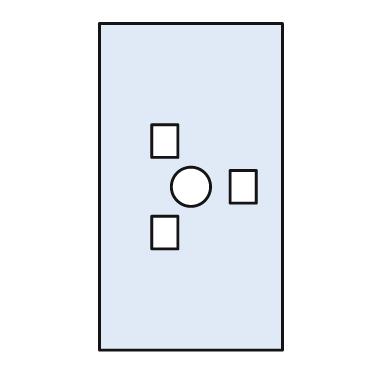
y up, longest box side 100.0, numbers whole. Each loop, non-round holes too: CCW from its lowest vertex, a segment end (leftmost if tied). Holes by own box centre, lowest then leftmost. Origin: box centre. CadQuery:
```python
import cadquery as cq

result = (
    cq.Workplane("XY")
    .moveTo(-28.0, -50.0)
    .lineTo(28.0, -50.0)
    .lineTo(28.0, 50.0)
    .lineTo(-28.0, 50.0)
    .close()
    .moveTo(-12.0, -19.0)
    .lineTo(-4.0, -19.0)
    .lineTo(-4.0, -9.0)
    .lineTo(-12.0, -9.0)
    .close()
    .moveTo(0.0, 0.0)
    .circle(6.0)
    .moveTo(12.0, -5.0)
    .lineTo(20.0, -5.0)
    .lineTo(20.0, 5.0)
    .lineTo(12.0, 5.0)
    .close()
    .moveTo(-12.0, 9.0)
    .lineTo(-4.0, 9.0)
    .lineTo(-4.0, 19.0)
    .lineTo(-12.0, 19.0)
    .close()
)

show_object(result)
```